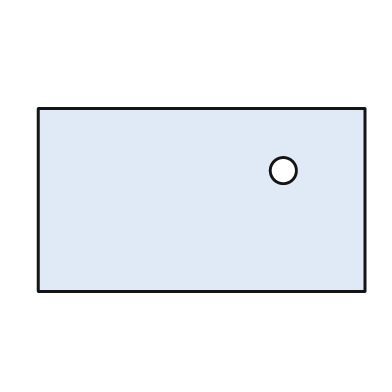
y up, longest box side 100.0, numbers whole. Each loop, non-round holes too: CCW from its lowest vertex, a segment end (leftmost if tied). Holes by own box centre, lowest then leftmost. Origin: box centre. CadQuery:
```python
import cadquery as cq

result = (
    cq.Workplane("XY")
    .moveTo(-50.0, -28.0)
    .lineTo(50.0, -28.0)
    .lineTo(50.0, 28.0)
    .lineTo(-50.0, 28.0)
    .close()
    .moveTo(25.0, 9.0)
    .circle(4.0)
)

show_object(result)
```